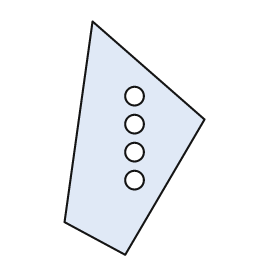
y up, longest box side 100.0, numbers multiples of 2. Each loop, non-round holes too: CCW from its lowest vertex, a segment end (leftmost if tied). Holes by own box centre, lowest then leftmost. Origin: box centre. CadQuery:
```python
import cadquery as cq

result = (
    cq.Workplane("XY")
    .moveTo(-4.0, -50.0)
    .lineTo(30.0, 8.0)
    .lineTo(-18.0, 50.0)
    .lineTo(-30.0, -36.0)
    .close()
    .moveTo(0.0, -18.0)
    .circle(4.0)
    .moveTo(0.0, -6.0)
    .circle(4.0)
    .moveTo(0.0, 6.0)
    .circle(4.0)
    .moveTo(0.0, 18.0)
    .circle(4.0)
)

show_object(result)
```